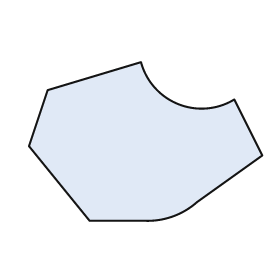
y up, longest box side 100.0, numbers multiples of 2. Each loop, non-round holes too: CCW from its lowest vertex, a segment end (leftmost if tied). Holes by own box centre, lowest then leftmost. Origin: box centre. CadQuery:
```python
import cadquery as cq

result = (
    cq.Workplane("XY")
    .moveTo(-24.0, -34.0)
    .lineTo(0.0, -34.0)
    .threePointArc((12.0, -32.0), (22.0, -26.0))
    .lineTo(50.0, -6.0)
    .lineTo(38.0, 18.0)
    .threePointArc((14.0, 16.0), (-2.0, 34.0))
    .lineTo(-42.0, 22.0)
    .lineTo(-50.0, -2.0)
    .close()
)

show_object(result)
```